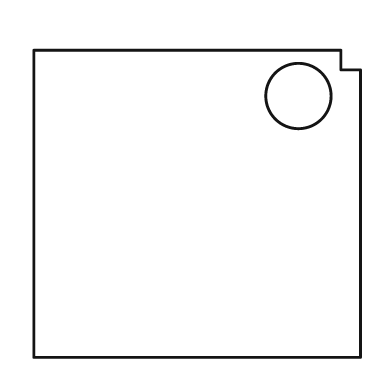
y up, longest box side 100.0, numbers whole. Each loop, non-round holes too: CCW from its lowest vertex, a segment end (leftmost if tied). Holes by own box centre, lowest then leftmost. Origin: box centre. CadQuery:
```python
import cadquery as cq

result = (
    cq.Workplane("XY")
    .moveTo(-50.0, -47.0)
    .lineTo(50.0, -47.0)
    .lineTo(50.0, 41.0)
    .lineTo(44.0, 41.0)
    .lineTo(44.0, 47.0)
    .lineTo(-50.0, 47.0)
    .close()
    .moveTo(31.0, 33.0)
    .circle(10.0)
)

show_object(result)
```